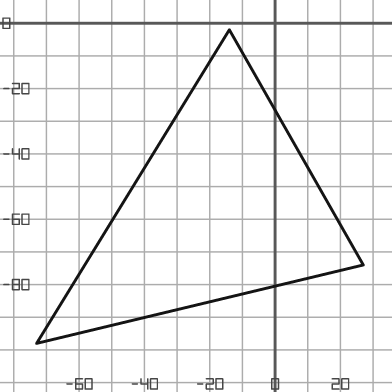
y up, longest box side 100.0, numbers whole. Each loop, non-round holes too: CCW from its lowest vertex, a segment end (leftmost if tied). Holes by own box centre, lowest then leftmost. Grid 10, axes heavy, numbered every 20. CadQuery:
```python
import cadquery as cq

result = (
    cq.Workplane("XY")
    .moveTo(-73.0, -98.0)
    .lineTo(27.0, -74.0)
    .lineTo(-14.0, -2.0)
    .close()
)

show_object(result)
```